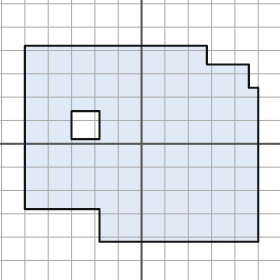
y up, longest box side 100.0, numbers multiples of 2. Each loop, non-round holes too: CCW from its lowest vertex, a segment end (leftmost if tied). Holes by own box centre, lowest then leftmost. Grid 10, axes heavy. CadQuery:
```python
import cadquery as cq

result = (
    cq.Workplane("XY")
    .moveTo(-18.0, -42.0)
    .lineTo(50.0, -42.0)
    .lineTo(50.0, 24.0)
    .lineTo(46.0, 24.0)
    .lineTo(46.0, 34.0)
    .lineTo(28.0, 34.0)
    .lineTo(28.0, 42.0)
    .lineTo(-50.0, 42.0)
    .lineTo(-50.0, -28.0)
    .lineTo(-18.0, -28.0)
    .close()
    .moveTo(-30.0, 2.0)
    .lineTo(-18.0, 2.0)
    .lineTo(-18.0, 14.0)
    .lineTo(-30.0, 14.0)
    .close()
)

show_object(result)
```